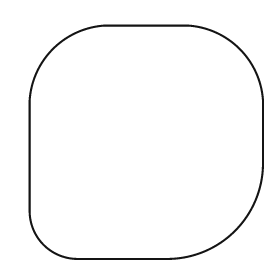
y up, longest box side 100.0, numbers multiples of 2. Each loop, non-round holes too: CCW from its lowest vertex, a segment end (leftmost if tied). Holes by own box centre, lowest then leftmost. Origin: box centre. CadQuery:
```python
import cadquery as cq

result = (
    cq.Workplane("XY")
    .moveTo(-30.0, -50.0)
    .lineTo(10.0, -50.0)
    .threePointArc((38.0, -38.0), (50.0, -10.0))
    .lineTo(50.0, 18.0)
    .threePointArc((40.0, 40.0), (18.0, 50.0))
    .lineTo(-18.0, 50.0)
    .threePointArc((-40.0, 40.0), (-50.0, 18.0))
    .lineTo(-50.0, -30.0)
    .threePointArc((-44.0, -44.0), (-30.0, -50.0))
    .close()
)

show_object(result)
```